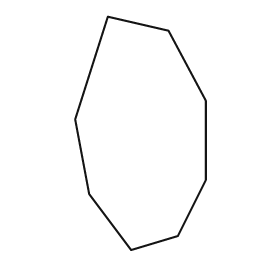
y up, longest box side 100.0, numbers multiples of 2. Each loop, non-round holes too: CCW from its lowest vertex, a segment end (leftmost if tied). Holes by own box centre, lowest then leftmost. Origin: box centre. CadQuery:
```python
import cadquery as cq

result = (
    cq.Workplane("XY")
    .moveTo(-4.0, -50.0)
    .lineTo(16.0, -44.0)
    .lineTo(28.0, -20.0)
    .lineTo(28.0, 14.0)
    .lineTo(12.0, 44.0)
    .lineTo(-14.0, 50.0)
    .lineTo(-28.0, 6.0)
    .lineTo(-22.0, -26.0)
    .close()
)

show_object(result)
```